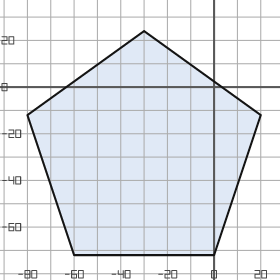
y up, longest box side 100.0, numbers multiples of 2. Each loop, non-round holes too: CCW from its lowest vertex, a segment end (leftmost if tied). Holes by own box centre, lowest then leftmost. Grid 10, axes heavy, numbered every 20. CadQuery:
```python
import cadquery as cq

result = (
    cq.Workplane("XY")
    .moveTo(-60.0, -72.0)
    .lineTo(0.0, -72.0)
    .lineTo(20.0, -12.0)
    .lineTo(-30.0, 24.0)
    .lineTo(-80.0, -12.0)
    .close()
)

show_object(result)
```